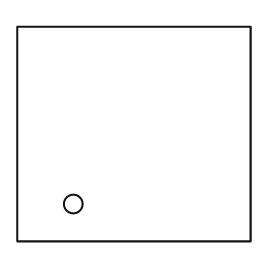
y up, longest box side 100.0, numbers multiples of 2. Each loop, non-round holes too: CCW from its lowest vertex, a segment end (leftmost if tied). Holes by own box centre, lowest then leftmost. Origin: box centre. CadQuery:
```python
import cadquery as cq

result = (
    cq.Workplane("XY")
    .moveTo(-50.0, -46.0)
    .lineTo(50.0, -46.0)
    .lineTo(50.0, 46.0)
    .lineTo(-50.0, 46.0)
    .close()
    .moveTo(-26.0, -30.0)
    .circle(4.0)
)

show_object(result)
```